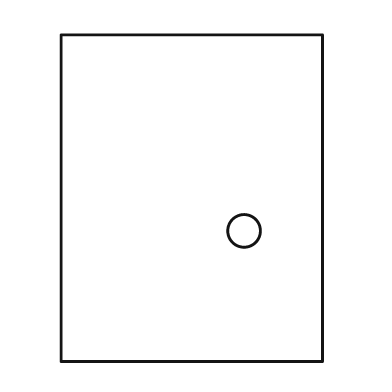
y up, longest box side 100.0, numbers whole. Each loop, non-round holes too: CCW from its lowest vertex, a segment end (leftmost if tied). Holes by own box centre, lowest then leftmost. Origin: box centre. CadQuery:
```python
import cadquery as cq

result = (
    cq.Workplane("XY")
    .moveTo(-40.0, -50.0)
    .lineTo(40.0, -50.0)
    .lineTo(40.0, 50.0)
    .lineTo(-40.0, 50.0)
    .close()
    .moveTo(16.0, -10.0)
    .circle(5.0)
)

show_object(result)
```